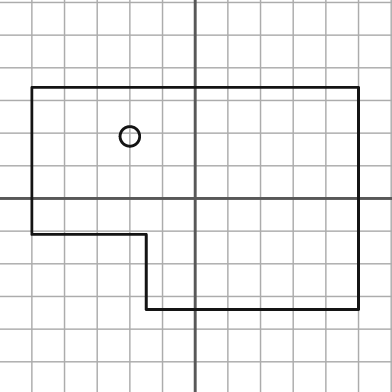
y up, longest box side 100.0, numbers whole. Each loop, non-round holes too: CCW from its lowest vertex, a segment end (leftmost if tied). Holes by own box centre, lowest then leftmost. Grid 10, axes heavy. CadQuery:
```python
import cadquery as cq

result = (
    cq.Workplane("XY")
    .moveTo(-15.0, -34.0)
    .lineTo(50.0, -34.0)
    .lineTo(50.0, 34.0)
    .lineTo(-50.0, 34.0)
    .lineTo(-50.0, -11.0)
    .lineTo(-15.0, -11.0)
    .close()
    .moveTo(-20.0, 19.0)
    .circle(3.0)
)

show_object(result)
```